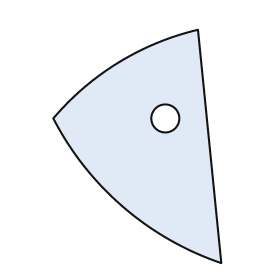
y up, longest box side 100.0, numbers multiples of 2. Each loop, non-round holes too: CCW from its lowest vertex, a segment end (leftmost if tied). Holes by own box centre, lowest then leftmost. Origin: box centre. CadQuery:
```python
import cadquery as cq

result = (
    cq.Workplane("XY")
    .moveTo(36.0, -50.0)
    .lineTo(26.0, 50.0)
    .threePointArc((-8.0, 36.0), (-36.0, 12.0))
    .threePointArc((-6.0, -26.0), (36.0, -50.0))
    .close()
    .moveTo(12.0, 12.0)
    .circle(6.0)
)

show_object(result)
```